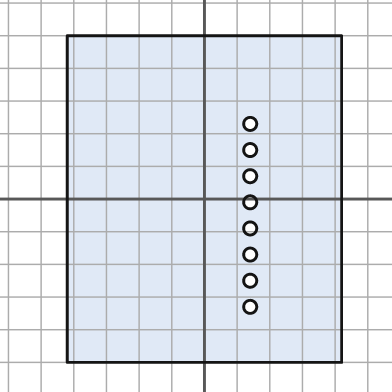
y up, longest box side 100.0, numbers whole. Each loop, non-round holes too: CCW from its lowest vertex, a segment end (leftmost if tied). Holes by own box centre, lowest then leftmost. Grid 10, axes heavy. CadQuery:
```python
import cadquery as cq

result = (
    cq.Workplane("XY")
    .moveTo(-42.0, -50.0)
    .lineTo(42.0, -50.0)
    .lineTo(42.0, 50.0)
    .lineTo(-42.0, 50.0)
    .close()
    .moveTo(14.0, -33.0)
    .circle(2.0)
    .moveTo(14.0, -25.0)
    .circle(2.0)
    .moveTo(14.0, -17.0)
    .circle(2.0)
    .moveTo(14.0, -9.0)
    .circle(2.0)
    .moveTo(14.0, -1.0)
    .circle(2.0)
    .moveTo(14.0, 7.0)
    .circle(2.0)
    .moveTo(14.0, 15.0)
    .circle(2.0)
    .moveTo(14.0, 23.0)
    .circle(2.0)
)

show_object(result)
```